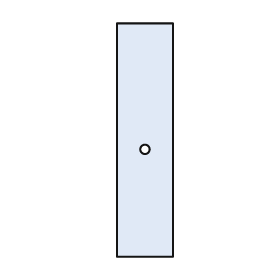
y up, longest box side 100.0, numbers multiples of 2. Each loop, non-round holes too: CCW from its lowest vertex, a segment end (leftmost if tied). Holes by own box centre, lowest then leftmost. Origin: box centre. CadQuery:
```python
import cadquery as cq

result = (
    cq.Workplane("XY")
    .moveTo(-12.0, -50.0)
    .lineTo(12.0, -50.0)
    .lineTo(12.0, 50.0)
    .lineTo(-12.0, 50.0)
    .close()
    .moveTo(0.0, -4.0)
    .circle(2.0)
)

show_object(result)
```